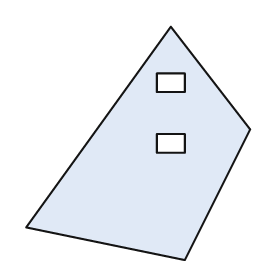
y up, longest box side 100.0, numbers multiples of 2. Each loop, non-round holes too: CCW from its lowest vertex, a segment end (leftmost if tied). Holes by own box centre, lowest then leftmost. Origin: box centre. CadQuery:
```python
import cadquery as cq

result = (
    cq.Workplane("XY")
    .moveTo(20.0, -50.0)
    .lineTo(48.0, 6.0)
    .lineTo(14.0, 50.0)
    .lineTo(-48.0, -36.0)
    .close()
    .moveTo(8.0, -4.0)
    .lineTo(20.0, -4.0)
    .lineTo(20.0, 4.0)
    .lineTo(8.0, 4.0)
    .close()
    .moveTo(8.0, 22.0)
    .lineTo(20.0, 22.0)
    .lineTo(20.0, 30.0)
    .lineTo(8.0, 30.0)
    .close()
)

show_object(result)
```